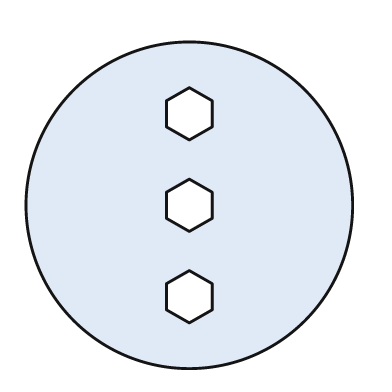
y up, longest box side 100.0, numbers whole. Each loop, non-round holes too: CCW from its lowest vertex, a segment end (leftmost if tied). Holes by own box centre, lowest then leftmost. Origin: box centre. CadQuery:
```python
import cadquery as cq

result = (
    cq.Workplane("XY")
    .moveTo(0.0, 0.0)
    .circle(50.0)
    .moveTo(0.0, -36.0)
    .lineTo(7.0, -32.0)
    .lineTo(7.0, -24.0)
    .lineTo(0.0, -20.0)
    .lineTo(-7.0, -24.0)
    .lineTo(-7.0, -32.0)
    .close()
    .moveTo(0.0, -8.0)
    .lineTo(7.0, -4.0)
    .lineTo(7.0, 4.0)
    .lineTo(0.0, 8.0)
    .lineTo(-7.0, 4.0)
    .lineTo(-7.0, -4.0)
    .close()
    .moveTo(0.0, 20.0)
    .lineTo(7.0, 24.0)
    .lineTo(7.0, 32.0)
    .lineTo(0.0, 36.0)
    .lineTo(-7.0, 32.0)
    .lineTo(-7.0, 24.0)
    .close()
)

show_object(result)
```